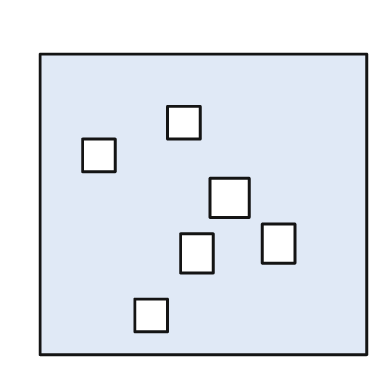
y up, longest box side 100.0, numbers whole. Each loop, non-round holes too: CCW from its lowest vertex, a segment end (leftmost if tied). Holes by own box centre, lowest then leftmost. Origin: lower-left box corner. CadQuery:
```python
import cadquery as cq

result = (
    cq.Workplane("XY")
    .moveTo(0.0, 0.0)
    .lineTo(100.0, 0.0)
    .lineTo(100.0, 92.0)
    .lineTo(0.0, 92.0)
    .close()
    .moveTo(29.0, 7.0)
    .lineTo(39.0, 7.0)
    .lineTo(39.0, 17.0)
    .lineTo(29.0, 17.0)
    .close()
    .moveTo(43.0, 25.0)
    .lineTo(53.0, 25.0)
    .lineTo(53.0, 37.0)
    .lineTo(43.0, 37.0)
    .close()
    .moveTo(68.0, 28.0)
    .lineTo(78.0, 28.0)
    .lineTo(78.0, 40.0)
    .lineTo(68.0, 40.0)
    .close()
    .moveTo(52.0, 42.0)
    .lineTo(64.0, 42.0)
    .lineTo(64.0, 54.0)
    .lineTo(52.0, 54.0)
    .close()
    .moveTo(13.0, 56.0)
    .lineTo(23.0, 56.0)
    .lineTo(23.0, 66.0)
    .lineTo(13.0, 66.0)
    .close()
    .moveTo(39.0, 66.0)
    .lineTo(49.0, 66.0)
    .lineTo(49.0, 76.0)
    .lineTo(39.0, 76.0)
    .close()
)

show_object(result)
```